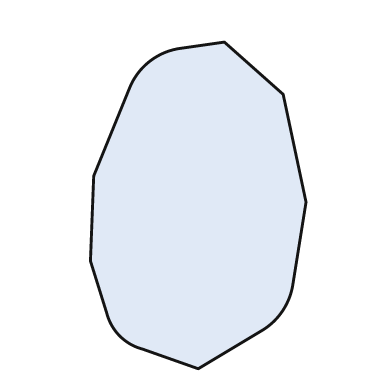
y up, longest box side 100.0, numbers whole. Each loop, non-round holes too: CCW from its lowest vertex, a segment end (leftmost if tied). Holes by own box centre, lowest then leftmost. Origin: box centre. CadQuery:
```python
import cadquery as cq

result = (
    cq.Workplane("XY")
    .moveTo(0.0, -50.0)
    .lineTo(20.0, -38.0)
    .threePointArc((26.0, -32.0), (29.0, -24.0))
    .lineTo(33.0, 1.0)
    .lineTo(26.0, 34.0)
    .lineTo(8.0, 50.0)
    .lineTo(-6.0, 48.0)
    .threePointArc((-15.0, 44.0), (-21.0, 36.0))
    .lineTo(-32.0, 9.0)
    .lineTo(-33.0, -17.0)
    .lineTo(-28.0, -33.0)
    .threePointArc((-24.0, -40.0), (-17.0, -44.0))
    .close()
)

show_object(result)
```